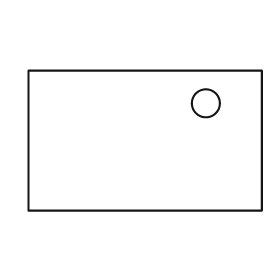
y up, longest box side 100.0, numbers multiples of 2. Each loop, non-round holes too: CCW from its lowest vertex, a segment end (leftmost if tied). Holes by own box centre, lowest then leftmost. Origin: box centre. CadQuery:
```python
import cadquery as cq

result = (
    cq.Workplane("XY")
    .moveTo(-50.0, -30.0)
    .lineTo(50.0, -30.0)
    .lineTo(50.0, 30.0)
    .lineTo(-50.0, 30.0)
    .close()
    .moveTo(26.0, 16.0)
    .circle(6.0)
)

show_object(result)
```